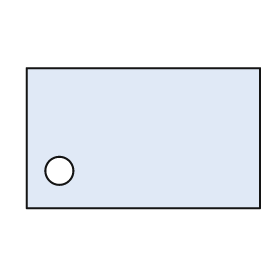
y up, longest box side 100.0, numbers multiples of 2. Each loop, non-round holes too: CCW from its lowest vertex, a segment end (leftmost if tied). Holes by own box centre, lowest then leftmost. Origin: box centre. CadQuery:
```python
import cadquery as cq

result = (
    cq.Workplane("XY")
    .moveTo(-50.0, -30.0)
    .lineTo(50.0, -30.0)
    .lineTo(50.0, 30.0)
    .lineTo(-50.0, 30.0)
    .close()
    .moveTo(-36.0, -14.0)
    .circle(6.0)
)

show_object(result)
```